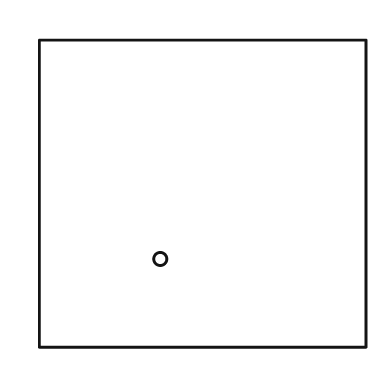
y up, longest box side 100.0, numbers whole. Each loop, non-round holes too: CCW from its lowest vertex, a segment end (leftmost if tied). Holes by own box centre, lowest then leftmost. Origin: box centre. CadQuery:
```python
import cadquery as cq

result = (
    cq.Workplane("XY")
    .moveTo(-50.0, -47.0)
    .lineTo(50.0, -47.0)
    .lineTo(50.0, 47.0)
    .lineTo(-50.0, 47.0)
    .close()
    .moveTo(-13.0, -20.0)
    .circle(2.0)
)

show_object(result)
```